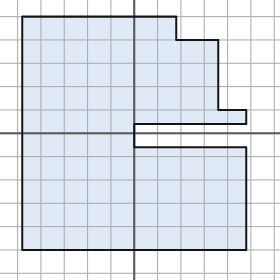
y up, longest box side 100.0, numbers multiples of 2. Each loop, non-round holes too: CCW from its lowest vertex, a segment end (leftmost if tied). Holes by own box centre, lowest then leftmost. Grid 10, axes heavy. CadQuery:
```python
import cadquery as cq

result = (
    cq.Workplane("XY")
    .moveTo(-48.0, -50.0)
    .lineTo(48.0, -50.0)
    .lineTo(48.0, -6.0)
    .lineTo(0.0, -6.0)
    .lineTo(0.0, 4.0)
    .lineTo(48.0, 4.0)
    .lineTo(48.0, 10.0)
    .lineTo(36.0, 10.0)
    .lineTo(36.0, 40.0)
    .lineTo(18.0, 40.0)
    .lineTo(18.0, 50.0)
    .lineTo(-48.0, 50.0)
    .close()
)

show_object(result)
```